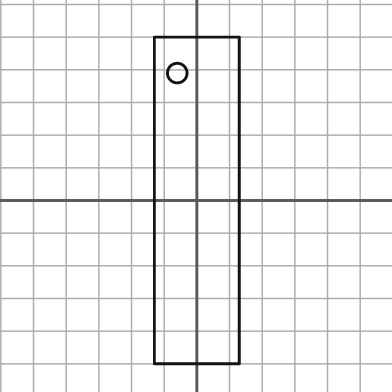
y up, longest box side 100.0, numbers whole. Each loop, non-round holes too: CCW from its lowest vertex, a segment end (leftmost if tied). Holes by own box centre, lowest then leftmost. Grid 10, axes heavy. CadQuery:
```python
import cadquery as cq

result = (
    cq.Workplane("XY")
    .moveTo(-13.0, -50.0)
    .lineTo(13.0, -50.0)
    .lineTo(13.0, 50.0)
    .lineTo(-13.0, 50.0)
    .close()
    .moveTo(-6.0, 39.0)
    .circle(3.0)
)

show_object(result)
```